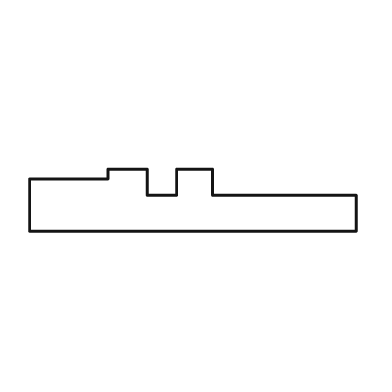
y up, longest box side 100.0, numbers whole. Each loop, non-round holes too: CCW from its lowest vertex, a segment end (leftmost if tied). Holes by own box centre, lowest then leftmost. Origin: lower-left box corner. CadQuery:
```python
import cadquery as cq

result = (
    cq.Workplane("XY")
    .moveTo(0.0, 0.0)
    .lineTo(100.0, 0.0)
    .lineTo(100.0, 11.0)
    .lineTo(56.0, 11.0)
    .lineTo(56.0, 19.0)
    .lineTo(45.0, 19.0)
    .lineTo(45.0, 11.0)
    .lineTo(36.0, 11.0)
    .lineTo(36.0, 19.0)
    .lineTo(24.0, 19.0)
    .lineTo(24.0, 16.0)
    .lineTo(0.0, 16.0)
    .close()
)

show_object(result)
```